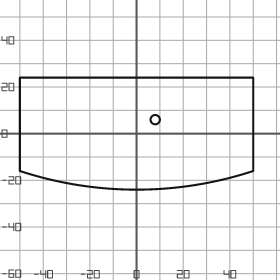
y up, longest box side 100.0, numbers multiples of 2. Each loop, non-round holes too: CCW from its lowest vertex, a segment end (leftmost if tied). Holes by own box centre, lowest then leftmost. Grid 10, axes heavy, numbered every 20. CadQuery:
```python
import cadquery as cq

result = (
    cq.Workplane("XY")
    .moveTo(-50.0, -16.0)
    .threePointArc((0.0, -24.0), (50.0, -16.0))
    .lineTo(50.0, 24.0)
    .lineTo(-50.0, 24.0)
    .close()
    .moveTo(8.0, 6.0)
    .circle(2.0)
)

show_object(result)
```